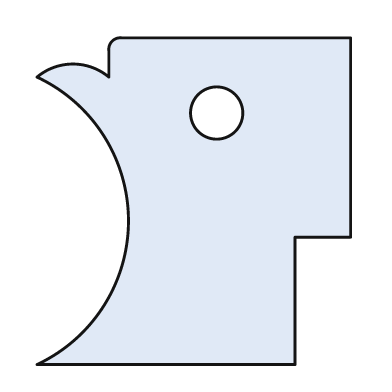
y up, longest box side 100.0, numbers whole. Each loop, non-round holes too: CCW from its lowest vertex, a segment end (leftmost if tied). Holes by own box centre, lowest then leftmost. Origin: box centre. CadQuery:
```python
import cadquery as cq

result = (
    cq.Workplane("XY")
    .moveTo(-48.0, -50.0)
    .lineTo(31.0, -50.0)
    .lineTo(31.0, -11.0)
    .lineTo(48.0, -11.0)
    .lineTo(48.0, 50.0)
    .lineTo(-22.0, 50.0)
    .threePointArc((-25.0, 49.0), (-26.0, 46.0))
    .lineTo(-26.0, 38.0)
    .threePointArc((-37.0, 42.0), (-48.0, 38.0))
    .threePointArc((-20.0, -6.0), (-48.0, -50.0))
    .close()
    .moveTo(7.0, 27.0)
    .circle(8.0)
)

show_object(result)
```